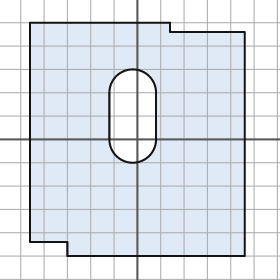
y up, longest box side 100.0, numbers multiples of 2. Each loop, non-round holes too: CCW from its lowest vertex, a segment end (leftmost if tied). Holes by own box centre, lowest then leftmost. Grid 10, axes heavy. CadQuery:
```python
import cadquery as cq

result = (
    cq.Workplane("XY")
    .moveTo(-30.0, -50.0)
    .lineTo(46.0, -50.0)
    .lineTo(46.0, 46.0)
    .lineTo(14.0, 46.0)
    .lineTo(14.0, 50.0)
    .lineTo(-46.0, 50.0)
    .lineTo(-46.0, -44.0)
    .lineTo(-30.0, -44.0)
    .close()
    .moveTo(-12.0, 0.0)
    .threePointArc((-2.0, -10.0), (8.0, 0.0))
    .lineTo(8.0, 20.0)
    .threePointArc((-2.0, 30.0), (-12.0, 20.0))
    .close()
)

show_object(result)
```